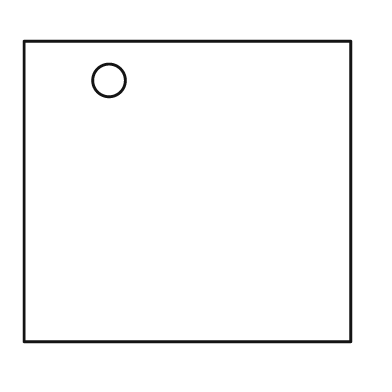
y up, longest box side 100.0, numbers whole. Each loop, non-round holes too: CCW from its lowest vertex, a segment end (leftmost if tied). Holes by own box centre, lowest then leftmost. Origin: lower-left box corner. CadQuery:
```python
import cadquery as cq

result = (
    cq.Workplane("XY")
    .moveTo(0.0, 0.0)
    .lineTo(100.0, 0.0)
    .lineTo(100.0, 92.0)
    .lineTo(0.0, 92.0)
    .close()
    .moveTo(26.0, 80.0)
    .circle(5.0)
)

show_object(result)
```